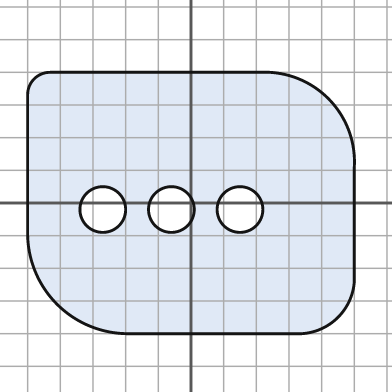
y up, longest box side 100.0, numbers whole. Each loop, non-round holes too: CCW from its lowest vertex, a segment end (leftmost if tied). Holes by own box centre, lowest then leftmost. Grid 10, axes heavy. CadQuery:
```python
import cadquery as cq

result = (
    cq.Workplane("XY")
    .moveTo(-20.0, -40.0)
    .lineTo(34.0, -40.0)
    .threePointArc((45.0, -35.0), (50.0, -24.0))
    .lineTo(50.0, 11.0)
    .threePointArc((42.0, 32.0), (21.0, 40.0))
    .lineTo(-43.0, 40.0)
    .threePointArc((-48.0, 38.0), (-50.0, 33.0))
    .lineTo(-50.0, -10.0)
    .threePointArc((-41.0, -31.0), (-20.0, -40.0))
    .close()
    .moveTo(-27.0, -2.0)
    .circle(7.0)
    .moveTo(-6.0, -2.0)
    .circle(7.0)
    .moveTo(15.0, -2.0)
    .circle(7.0)
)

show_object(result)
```